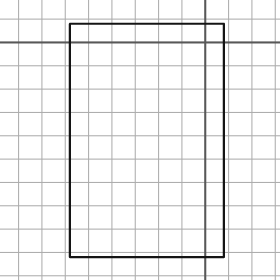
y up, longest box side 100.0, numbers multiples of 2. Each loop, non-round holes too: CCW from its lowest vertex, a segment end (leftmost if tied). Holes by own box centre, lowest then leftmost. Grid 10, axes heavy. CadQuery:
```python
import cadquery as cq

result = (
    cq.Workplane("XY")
    .moveTo(-58.0, -92.0)
    .lineTo(8.0, -92.0)
    .lineTo(8.0, 8.0)
    .lineTo(-58.0, 8.0)
    .close()
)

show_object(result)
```